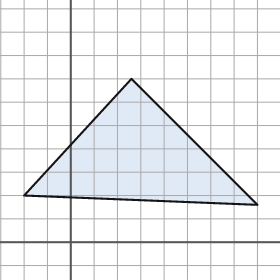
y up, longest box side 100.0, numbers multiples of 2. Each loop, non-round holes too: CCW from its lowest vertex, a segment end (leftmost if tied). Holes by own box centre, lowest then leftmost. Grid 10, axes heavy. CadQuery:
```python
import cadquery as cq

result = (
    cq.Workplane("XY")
    .moveTo(80.0, 16.0)
    .lineTo(26.0, 70.0)
    .lineTo(-20.0, 20.0)
    .close()
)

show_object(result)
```